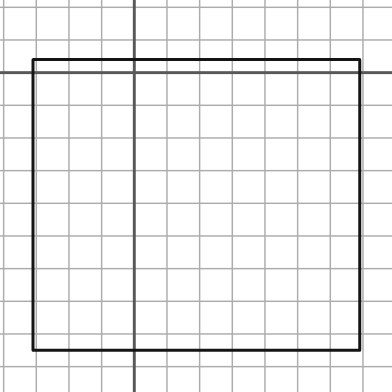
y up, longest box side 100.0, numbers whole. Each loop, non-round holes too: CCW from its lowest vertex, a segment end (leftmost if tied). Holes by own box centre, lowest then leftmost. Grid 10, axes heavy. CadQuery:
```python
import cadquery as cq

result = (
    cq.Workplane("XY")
    .moveTo(-31.0, -85.0)
    .lineTo(69.0, -85.0)
    .lineTo(69.0, 4.0)
    .lineTo(-31.0, 4.0)
    .close()
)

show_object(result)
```